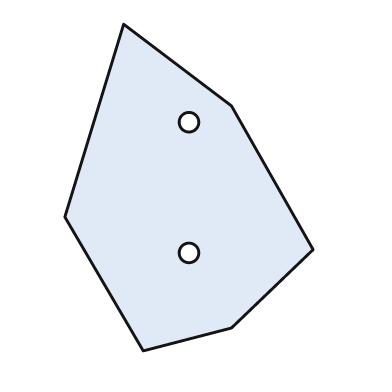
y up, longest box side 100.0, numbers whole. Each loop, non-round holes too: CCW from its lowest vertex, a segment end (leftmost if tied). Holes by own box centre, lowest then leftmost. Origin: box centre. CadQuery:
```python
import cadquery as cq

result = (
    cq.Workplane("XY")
    .moveTo(-14.0, -50.0)
    .lineTo(13.0, -43.0)
    .lineTo(38.0, -19.0)
    .lineTo(13.0, 25.0)
    .lineTo(-20.0, 50.0)
    .lineTo(-38.0, -9.0)
    .close()
    .moveTo(0.0, -20.0)
    .circle(3.0)
    .moveTo(0.0, 20.0)
    .circle(3.0)
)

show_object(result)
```